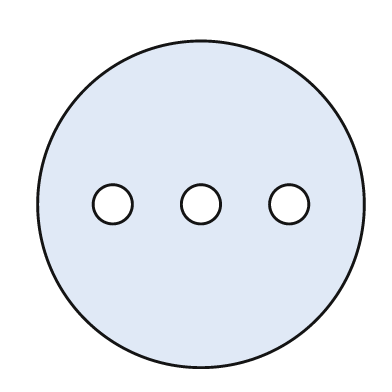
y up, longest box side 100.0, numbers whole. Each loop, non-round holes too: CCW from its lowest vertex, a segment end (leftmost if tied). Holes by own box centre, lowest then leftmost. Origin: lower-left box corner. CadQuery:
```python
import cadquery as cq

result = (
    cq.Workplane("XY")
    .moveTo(50.0, 50.0)
    .circle(50.0)
    .moveTo(23.0, 50.0)
    .circle(6.0)
    .moveTo(50.0, 50.0)
    .circle(6.0)
    .moveTo(77.0, 50.0)
    .circle(6.0)
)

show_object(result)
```